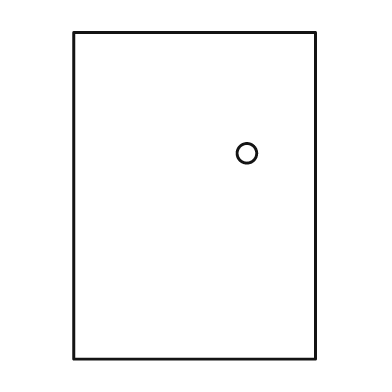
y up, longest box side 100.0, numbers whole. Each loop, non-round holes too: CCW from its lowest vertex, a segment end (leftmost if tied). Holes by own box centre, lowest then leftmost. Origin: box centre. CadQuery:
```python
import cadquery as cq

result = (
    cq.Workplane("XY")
    .moveTo(-37.0, -50.0)
    .lineTo(37.0, -50.0)
    .lineTo(37.0, 50.0)
    .lineTo(-37.0, 50.0)
    .close()
    .moveTo(16.0, 13.0)
    .circle(3.0)
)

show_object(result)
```